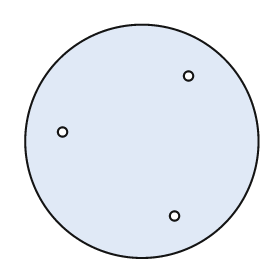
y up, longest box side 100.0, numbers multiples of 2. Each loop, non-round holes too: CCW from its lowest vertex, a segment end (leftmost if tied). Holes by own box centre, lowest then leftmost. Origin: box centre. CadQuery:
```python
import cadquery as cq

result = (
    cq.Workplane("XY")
    .moveTo(0.0, 0.0)
    .circle(50.0)
    .moveTo(14.0, -32.0)
    .circle(2.0)
    .moveTo(-34.0, 4.0)
    .circle(2.0)
    .moveTo(20.0, 28.0)
    .circle(2.0)
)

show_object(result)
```